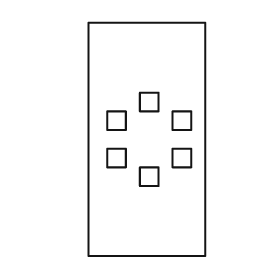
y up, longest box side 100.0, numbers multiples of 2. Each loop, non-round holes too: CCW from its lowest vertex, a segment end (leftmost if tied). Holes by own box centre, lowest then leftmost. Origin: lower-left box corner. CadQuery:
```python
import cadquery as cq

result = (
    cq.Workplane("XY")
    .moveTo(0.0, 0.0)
    .lineTo(50.0, 0.0)
    .lineTo(50.0, 100.0)
    .lineTo(0.0, 100.0)
    .close()
    .moveTo(22.0, 30.0)
    .lineTo(30.0, 30.0)
    .lineTo(30.0, 38.0)
    .lineTo(22.0, 38.0)
    .close()
    .moveTo(8.0, 38.0)
    .lineTo(16.0, 38.0)
    .lineTo(16.0, 46.0)
    .lineTo(8.0, 46.0)
    .close()
    .moveTo(36.0, 38.0)
    .lineTo(44.0, 38.0)
    .lineTo(44.0, 46.0)
    .lineTo(36.0, 46.0)
    .close()
    .moveTo(8.0, 54.0)
    .lineTo(16.0, 54.0)
    .lineTo(16.0, 62.0)
    .lineTo(8.0, 62.0)
    .close()
    .moveTo(36.0, 54.0)
    .lineTo(44.0, 54.0)
    .lineTo(44.0, 62.0)
    .lineTo(36.0, 62.0)
    .close()
    .moveTo(22.0, 62.0)
    .lineTo(30.0, 62.0)
    .lineTo(30.0, 70.0)
    .lineTo(22.0, 70.0)
    .close()
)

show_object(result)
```